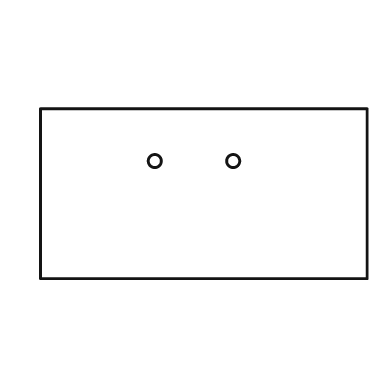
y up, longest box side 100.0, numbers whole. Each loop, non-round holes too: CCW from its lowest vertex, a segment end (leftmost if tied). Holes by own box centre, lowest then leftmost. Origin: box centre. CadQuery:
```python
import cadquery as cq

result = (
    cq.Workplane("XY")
    .moveTo(-50.0, -26.0)
    .lineTo(50.0, -26.0)
    .lineTo(50.0, 26.0)
    .lineTo(-50.0, 26.0)
    .close()
    .moveTo(-15.0, 10.0)
    .circle(2.0)
    .moveTo(9.0, 10.0)
    .circle(2.0)
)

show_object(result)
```